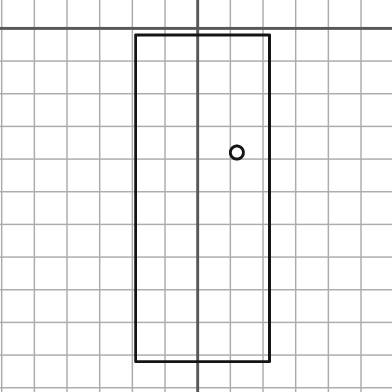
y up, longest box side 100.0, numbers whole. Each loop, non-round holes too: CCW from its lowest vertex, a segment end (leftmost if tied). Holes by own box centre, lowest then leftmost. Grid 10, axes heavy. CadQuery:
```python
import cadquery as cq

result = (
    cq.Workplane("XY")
    .moveTo(-19.0, -102.0)
    .lineTo(22.0, -102.0)
    .lineTo(22.0, -2.0)
    .lineTo(-19.0, -2.0)
    .close()
    .moveTo(12.0, -38.0)
    .circle(2.0)
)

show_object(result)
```